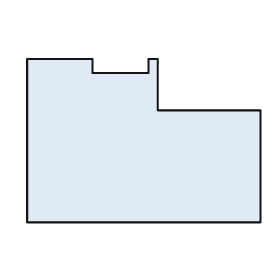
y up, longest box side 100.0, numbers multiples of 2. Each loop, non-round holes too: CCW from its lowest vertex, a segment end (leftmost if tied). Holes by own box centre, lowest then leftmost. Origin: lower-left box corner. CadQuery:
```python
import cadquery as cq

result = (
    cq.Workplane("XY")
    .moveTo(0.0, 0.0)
    .lineTo(100.0, 0.0)
    .lineTo(100.0, 48.0)
    .lineTo(56.0, 48.0)
    .lineTo(56.0, 70.0)
    .lineTo(52.0, 70.0)
    .lineTo(52.0, 64.0)
    .lineTo(28.0, 64.0)
    .lineTo(28.0, 70.0)
    .lineTo(0.0, 70.0)
    .close()
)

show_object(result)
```